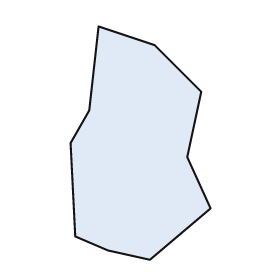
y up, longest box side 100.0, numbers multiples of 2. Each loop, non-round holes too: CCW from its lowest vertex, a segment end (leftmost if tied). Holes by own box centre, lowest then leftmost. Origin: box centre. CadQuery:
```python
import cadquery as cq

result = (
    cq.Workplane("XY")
    .moveTo(4.0, -50.0)
    .lineTo(30.0, -28.0)
    .lineTo(20.0, -6.0)
    .lineTo(26.0, 22.0)
    .lineTo(6.0, 42.0)
    .lineTo(-18.0, 50.0)
    .lineTo(-22.0, 14.0)
    .lineTo(-30.0, 0.0)
    .lineTo(-28.0, -40.0)
    .lineTo(-14.0, -46.0)
    .close()
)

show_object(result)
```